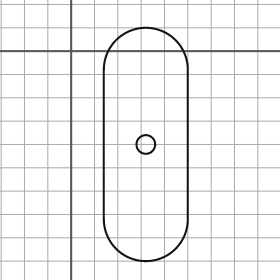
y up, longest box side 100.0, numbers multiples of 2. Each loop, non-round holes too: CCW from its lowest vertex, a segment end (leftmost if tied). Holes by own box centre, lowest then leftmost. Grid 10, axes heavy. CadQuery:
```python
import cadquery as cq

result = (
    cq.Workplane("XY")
    .moveTo(14.0, -72.0)
    .threePointArc((32.0, -90.0), (50.0, -72.0))
    .lineTo(50.0, -8.0)
    .threePointArc((32.0, 10.0), (14.0, -8.0))
    .close()
    .moveTo(32.0, -40.0)
    .circle(4.0)
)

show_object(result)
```